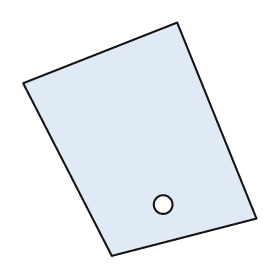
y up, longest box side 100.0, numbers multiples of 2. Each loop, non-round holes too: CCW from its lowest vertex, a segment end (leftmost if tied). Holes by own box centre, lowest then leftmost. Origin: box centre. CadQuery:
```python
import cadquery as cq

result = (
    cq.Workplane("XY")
    .moveTo(-12.0, -50.0)
    .lineTo(50.0, -34.0)
    .lineTo(16.0, 50.0)
    .lineTo(-50.0, 24.0)
    .close()
    .moveTo(10.0, -28.0)
    .circle(4.0)
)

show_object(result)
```